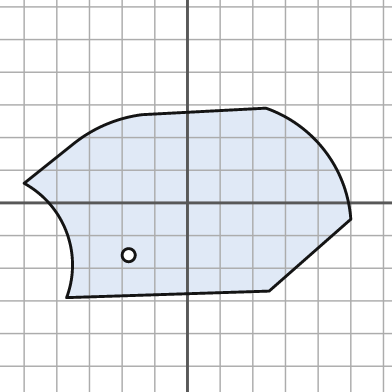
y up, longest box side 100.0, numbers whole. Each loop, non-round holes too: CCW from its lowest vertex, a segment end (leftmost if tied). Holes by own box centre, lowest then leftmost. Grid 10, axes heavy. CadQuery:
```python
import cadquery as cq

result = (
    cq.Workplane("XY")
    .moveTo(-37.0, -29.0)
    .lineTo(25.0, -27.0)
    .lineTo(50.0, -5.0)
    .threePointArc((42.0, 16.0), (24.0, 29.0))
    .lineTo(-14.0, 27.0)
    .threePointArc((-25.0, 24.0), (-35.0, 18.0))
    .lineTo(-50.0, 6.0)
    .threePointArc((-37.0, -9.0), (-37.0, -29.0))
    .close()
    .moveTo(-18.0, -16.0)
    .circle(2.0)
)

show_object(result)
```